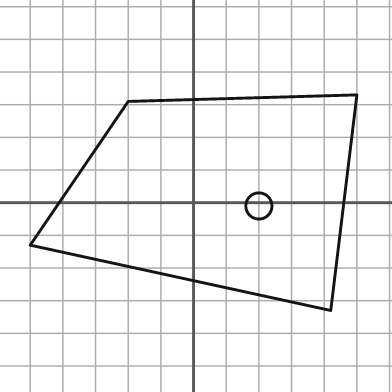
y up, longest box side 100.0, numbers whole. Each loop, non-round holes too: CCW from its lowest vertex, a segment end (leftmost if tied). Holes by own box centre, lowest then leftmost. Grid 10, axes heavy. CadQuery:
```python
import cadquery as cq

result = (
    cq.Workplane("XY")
    .moveTo(42.0, -33.0)
    .lineTo(50.0, 33.0)
    .lineTo(-20.0, 31.0)
    .lineTo(-50.0, -13.0)
    .close()
    .moveTo(20.0, -1.0)
    .circle(4.0)
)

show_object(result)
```